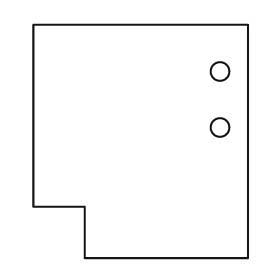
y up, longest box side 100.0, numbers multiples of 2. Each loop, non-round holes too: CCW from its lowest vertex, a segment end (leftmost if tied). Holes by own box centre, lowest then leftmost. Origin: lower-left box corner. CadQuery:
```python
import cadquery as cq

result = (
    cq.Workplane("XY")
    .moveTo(22.0, 0.0)
    .lineTo(92.0, 0.0)
    .lineTo(92.0, 100.0)
    .lineTo(0.0, 100.0)
    .lineTo(0.0, 22.0)
    .lineTo(22.0, 22.0)
    .close()
    .moveTo(80.0, 56.0)
    .circle(4.0)
    .moveTo(80.0, 80.0)
    .circle(4.0)
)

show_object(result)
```